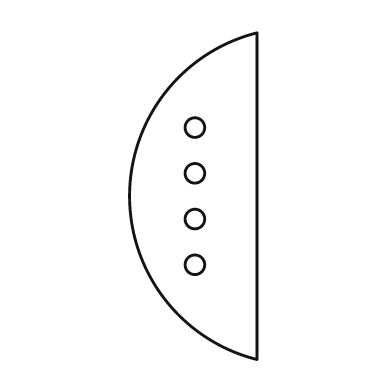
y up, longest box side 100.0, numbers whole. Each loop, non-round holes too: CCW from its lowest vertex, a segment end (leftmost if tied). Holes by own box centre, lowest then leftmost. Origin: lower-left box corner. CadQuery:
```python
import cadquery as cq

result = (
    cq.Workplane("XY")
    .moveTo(39.0, 0.0)
    .lineTo(39.0, 100.0)
    .threePointArc((0.0, 50.0), (39.0, 0.0))
    .close()
    .moveTo(20.0, 29.0)
    .circle(3.0)
    .moveTo(20.0, 43.0)
    .circle(3.0)
    .moveTo(20.0, 57.0)
    .circle(3.0)
    .moveTo(20.0, 71.0)
    .circle(3.0)
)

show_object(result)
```